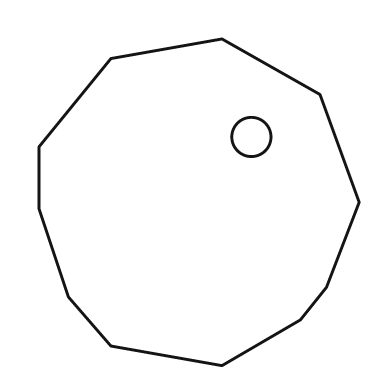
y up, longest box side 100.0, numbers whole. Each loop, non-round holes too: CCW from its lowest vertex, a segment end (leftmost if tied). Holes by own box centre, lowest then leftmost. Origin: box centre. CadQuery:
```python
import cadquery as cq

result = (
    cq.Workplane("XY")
    .moveTo(7.0, -50.0)
    .lineTo(31.0, -36.0)
    .lineTo(39.0, -26.0)
    .lineTo(49.0, 0.0)
    .lineTo(37.0, 33.0)
    .lineTo(7.0, 50.0)
    .lineTo(-27.0, 44.0)
    .lineTo(-49.0, 17.0)
    .lineTo(-49.0, -2.0)
    .lineTo(-40.0, -29.0)
    .lineTo(-27.0, -44.0)
    .close()
    .moveTo(16.0, 20.0)
    .circle(6.0)
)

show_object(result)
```